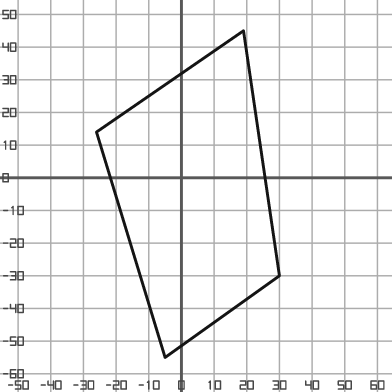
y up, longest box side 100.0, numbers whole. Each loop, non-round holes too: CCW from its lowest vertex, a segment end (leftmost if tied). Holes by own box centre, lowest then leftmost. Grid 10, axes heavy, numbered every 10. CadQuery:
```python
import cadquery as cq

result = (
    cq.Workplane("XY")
    .moveTo(-5.0, -55.0)
    .lineTo(30.0, -30.0)
    .lineTo(19.0, 45.0)
    .lineTo(-26.0, 14.0)
    .close()
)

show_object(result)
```